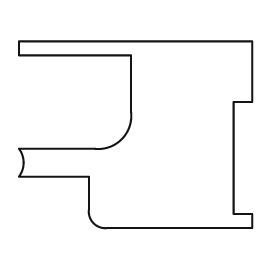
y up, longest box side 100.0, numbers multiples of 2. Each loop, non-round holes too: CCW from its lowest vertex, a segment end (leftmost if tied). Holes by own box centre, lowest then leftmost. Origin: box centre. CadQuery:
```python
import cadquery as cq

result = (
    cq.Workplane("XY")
    .moveTo(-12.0, -40.0)
    .lineTo(50.0, -40.0)
    .lineTo(50.0, -34.0)
    .lineTo(42.0, -34.0)
    .lineTo(42.0, 14.0)
    .lineTo(50.0, 14.0)
    .lineTo(50.0, 40.0)
    .lineTo(-50.0, 40.0)
    .lineTo(-50.0, 34.0)
    .lineTo(-2.0, 34.0)
    .lineTo(-2.0, 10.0)
    .threePointArc((-6.0, -2.0), (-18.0, -6.0))
    .lineTo(-50.0, -6.0)
    .threePointArc((-48.0, -12.0), (-50.0, -18.0))
    .lineTo(-20.0, -18.0)
    .lineTo(-20.0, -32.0)
    .threePointArc((-18.0, -38.0), (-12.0, -40.0))
    .close()
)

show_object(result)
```